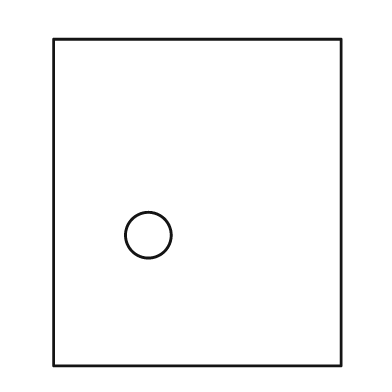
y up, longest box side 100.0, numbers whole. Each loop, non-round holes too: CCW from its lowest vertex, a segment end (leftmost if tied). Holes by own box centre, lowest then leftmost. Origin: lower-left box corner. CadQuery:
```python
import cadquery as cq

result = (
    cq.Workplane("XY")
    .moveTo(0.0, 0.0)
    .lineTo(88.0, 0.0)
    .lineTo(88.0, 100.0)
    .lineTo(0.0, 100.0)
    .close()
    .moveTo(29.0, 40.0)
    .circle(7.0)
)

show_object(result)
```